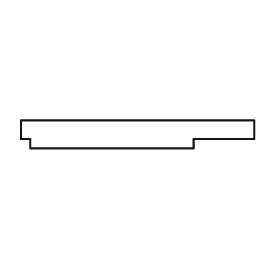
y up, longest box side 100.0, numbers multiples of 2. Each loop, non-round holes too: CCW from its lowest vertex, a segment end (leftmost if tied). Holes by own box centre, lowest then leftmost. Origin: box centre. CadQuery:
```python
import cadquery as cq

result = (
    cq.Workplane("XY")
    .moveTo(-46.0, -6.0)
    .lineTo(24.0, -6.0)
    .lineTo(24.0, -2.0)
    .lineTo(50.0, -2.0)
    .lineTo(50.0, 6.0)
    .lineTo(-50.0, 6.0)
    .lineTo(-50.0, -2.0)
    .lineTo(-46.0, -2.0)
    .close()
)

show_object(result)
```